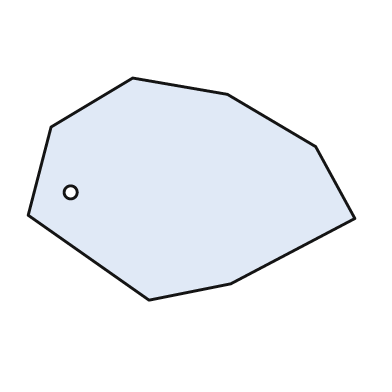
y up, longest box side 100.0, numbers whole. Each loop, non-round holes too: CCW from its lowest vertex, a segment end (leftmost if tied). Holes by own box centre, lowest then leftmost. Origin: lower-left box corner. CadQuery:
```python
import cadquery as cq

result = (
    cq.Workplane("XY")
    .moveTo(37.0, 0.0)
    .lineTo(62.0, 5.0)
    .lineTo(100.0, 25.0)
    .lineTo(88.0, 47.0)
    .lineTo(61.0, 63.0)
    .lineTo(32.0, 68.0)
    .lineTo(7.0, 53.0)
    .lineTo(0.0, 26.0)
    .close()
    .moveTo(13.0, 33.0)
    .circle(2.0)
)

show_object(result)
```